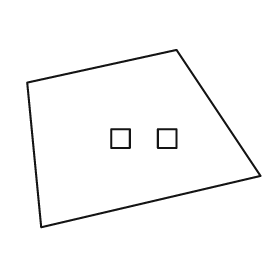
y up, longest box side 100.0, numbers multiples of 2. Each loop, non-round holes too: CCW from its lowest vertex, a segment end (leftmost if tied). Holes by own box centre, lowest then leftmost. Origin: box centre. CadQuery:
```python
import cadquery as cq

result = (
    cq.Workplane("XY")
    .moveTo(-44.0, -38.0)
    .lineTo(50.0, -16.0)
    .lineTo(14.0, 38.0)
    .lineTo(-50.0, 24.0)
    .close()
    .moveTo(-14.0, -4.0)
    .lineTo(-6.0, -4.0)
    .lineTo(-6.0, 4.0)
    .lineTo(-14.0, 4.0)
    .close()
    .moveTo(6.0, -4.0)
    .lineTo(14.0, -4.0)
    .lineTo(14.0, 4.0)
    .lineTo(6.0, 4.0)
    .close()
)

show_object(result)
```